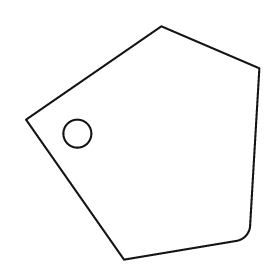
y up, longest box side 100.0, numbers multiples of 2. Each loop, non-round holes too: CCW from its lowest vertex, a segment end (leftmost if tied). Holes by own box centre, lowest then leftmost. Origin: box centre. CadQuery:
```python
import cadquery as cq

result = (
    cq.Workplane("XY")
    .moveTo(-8.0, -50.0)
    .lineTo(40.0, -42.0)
    .threePointArc((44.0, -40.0), (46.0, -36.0))
    .lineTo(50.0, 32.0)
    .lineTo(8.0, 50.0)
    .lineTo(-50.0, 10.0)
    .close()
    .moveTo(-28.0, 4.0)
    .circle(6.0)
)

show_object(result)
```